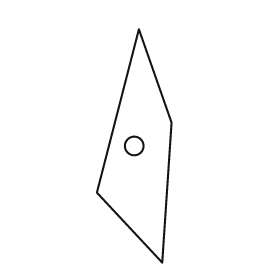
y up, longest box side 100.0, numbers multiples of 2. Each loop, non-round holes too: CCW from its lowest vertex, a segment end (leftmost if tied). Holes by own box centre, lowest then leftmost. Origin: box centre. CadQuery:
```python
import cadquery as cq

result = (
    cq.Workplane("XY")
    .moveTo(12.0, -50.0)
    .lineTo(16.0, 10.0)
    .lineTo(2.0, 50.0)
    .lineTo(-16.0, -20.0)
    .close()
    .moveTo(0.0, 0.0)
    .circle(4.0)
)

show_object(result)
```